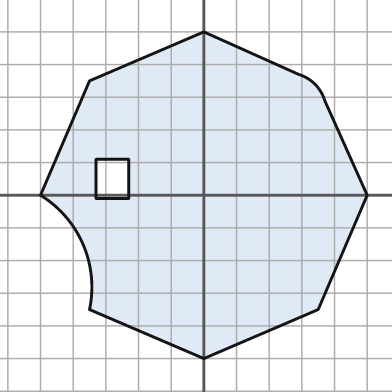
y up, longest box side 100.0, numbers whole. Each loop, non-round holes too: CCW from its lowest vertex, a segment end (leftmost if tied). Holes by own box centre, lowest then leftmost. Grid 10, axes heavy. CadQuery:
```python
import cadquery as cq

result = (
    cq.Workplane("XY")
    .moveTo(0.0, -50.0)
    .lineTo(35.0, -35.0)
    .lineTo(50.0, 0.0)
    .lineTo(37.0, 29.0)
    .threePointArc((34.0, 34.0), (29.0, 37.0))
    .lineTo(0.0, 50.0)
    .lineTo(-35.0, 35.0)
    .lineTo(-50.0, 0.0)
    .threePointArc((-37.0, -15.0), (-35.0, -35.0))
    .close()
    .moveTo(-33.0, -1.0)
    .lineTo(-23.0, -1.0)
    .lineTo(-23.0, 11.0)
    .lineTo(-33.0, 11.0)
    .close()
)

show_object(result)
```